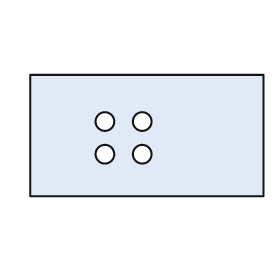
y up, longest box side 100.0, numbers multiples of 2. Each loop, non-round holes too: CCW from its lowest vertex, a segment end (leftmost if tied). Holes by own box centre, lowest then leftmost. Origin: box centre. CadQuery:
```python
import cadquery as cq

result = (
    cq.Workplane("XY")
    .moveTo(-50.0, -26.0)
    .lineTo(50.0, -26.0)
    .lineTo(50.0, 26.0)
    .lineTo(-50.0, 26.0)
    .close()
    .moveTo(-18.0, -8.0)
    .circle(4.0)
    .moveTo(-2.0, -8.0)
    .circle(4.0)
    .moveTo(-18.0, 6.0)
    .circle(4.0)
    .moveTo(-2.0, 6.0)
    .circle(4.0)
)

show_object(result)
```